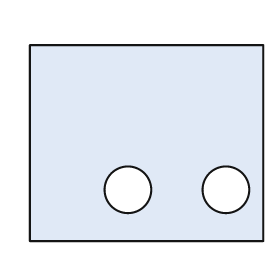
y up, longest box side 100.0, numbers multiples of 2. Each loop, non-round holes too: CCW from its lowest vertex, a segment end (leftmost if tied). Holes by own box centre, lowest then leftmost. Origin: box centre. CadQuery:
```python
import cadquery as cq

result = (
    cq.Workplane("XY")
    .moveTo(-50.0, -42.0)
    .lineTo(50.0, -42.0)
    .lineTo(50.0, 42.0)
    .lineTo(-50.0, 42.0)
    .close()
    .moveTo(-8.0, -20.0)
    .circle(10.0)
    .moveTo(34.0, -20.0)
    .circle(10.0)
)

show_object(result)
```